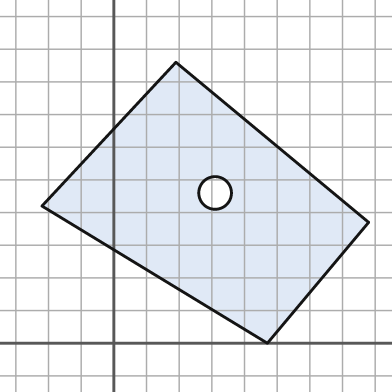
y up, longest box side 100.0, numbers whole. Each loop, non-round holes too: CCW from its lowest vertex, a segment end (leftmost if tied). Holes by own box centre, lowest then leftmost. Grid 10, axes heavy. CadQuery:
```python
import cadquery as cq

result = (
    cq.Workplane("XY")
    .moveTo(47.0, 0.0)
    .lineTo(78.0, 37.0)
    .lineTo(19.0, 86.0)
    .lineTo(-22.0, 42.0)
    .close()
    .moveTo(31.0, 46.0)
    .circle(5.0)
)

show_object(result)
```